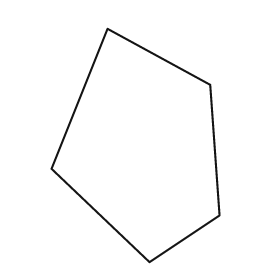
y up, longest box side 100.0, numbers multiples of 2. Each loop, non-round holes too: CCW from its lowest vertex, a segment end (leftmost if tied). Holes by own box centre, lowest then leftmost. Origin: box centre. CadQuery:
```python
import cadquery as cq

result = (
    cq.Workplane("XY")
    .moveTo(6.0, -50.0)
    .lineTo(36.0, -30.0)
    .lineTo(32.0, 26.0)
    .lineTo(-12.0, 50.0)
    .lineTo(-36.0, -10.0)
    .close()
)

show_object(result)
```